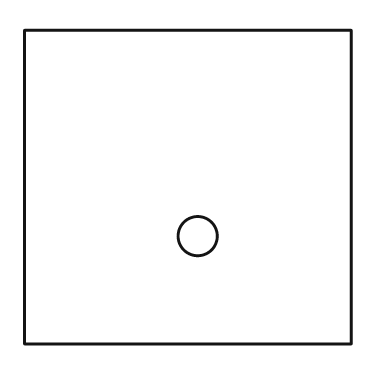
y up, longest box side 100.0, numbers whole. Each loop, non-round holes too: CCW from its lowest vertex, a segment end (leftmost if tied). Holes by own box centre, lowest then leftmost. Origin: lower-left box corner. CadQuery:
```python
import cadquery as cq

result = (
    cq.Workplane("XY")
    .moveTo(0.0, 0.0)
    .lineTo(100.0, 0.0)
    .lineTo(100.0, 96.0)
    .lineTo(0.0, 96.0)
    .close()
    .moveTo(53.0, 33.0)
    .circle(6.0)
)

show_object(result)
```